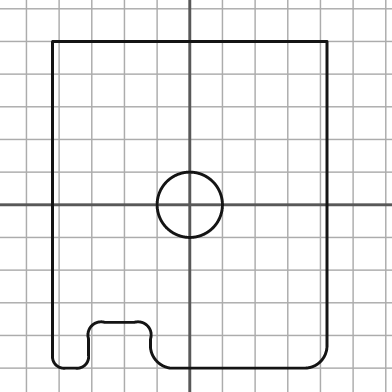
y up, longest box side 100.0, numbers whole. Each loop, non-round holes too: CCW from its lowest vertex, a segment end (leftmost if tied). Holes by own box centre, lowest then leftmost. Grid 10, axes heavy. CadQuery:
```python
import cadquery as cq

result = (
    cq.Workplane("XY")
    .moveTo(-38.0, -50.0)
    .lineTo(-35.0, -50.0)
    .threePointArc((-32.0, -49.0), (-31.0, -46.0))
    .lineTo(-31.0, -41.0)
    .threePointArc((-30.0, -37.0), (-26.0, -36.0))
    .lineTo(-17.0, -36.0)
    .threePointArc((-13.0, -37.0), (-12.0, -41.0))
    .lineTo(-12.0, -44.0)
    .threePointArc((-10.0, -48.0), (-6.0, -50.0))
    .lineTo(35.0, -50.0)
    .threePointArc((40.0, -48.0), (42.0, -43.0))
    .lineTo(42.0, 50.0)
    .lineTo(-42.0, 50.0)
    .lineTo(-42.0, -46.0)
    .threePointArc((-41.0, -49.0), (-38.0, -50.0))
    .close()
    .moveTo(0.0, 0.0)
    .circle(10.0)
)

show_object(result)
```